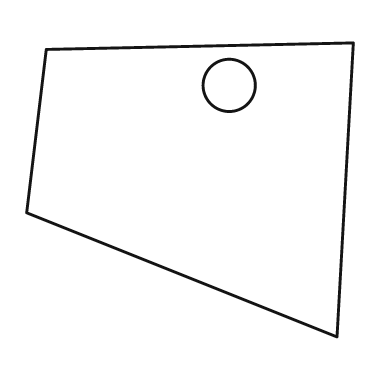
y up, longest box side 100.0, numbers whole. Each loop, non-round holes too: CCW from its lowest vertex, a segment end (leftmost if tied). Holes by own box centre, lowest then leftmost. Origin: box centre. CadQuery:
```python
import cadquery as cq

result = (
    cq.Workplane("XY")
    .moveTo(45.0, -45.0)
    .lineTo(50.0, 45.0)
    .lineTo(-44.0, 43.0)
    .lineTo(-50.0, -7.0)
    .close()
    .moveTo(12.0, 32.0)
    .circle(8.0)
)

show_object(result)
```